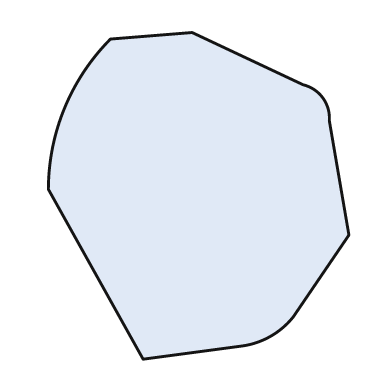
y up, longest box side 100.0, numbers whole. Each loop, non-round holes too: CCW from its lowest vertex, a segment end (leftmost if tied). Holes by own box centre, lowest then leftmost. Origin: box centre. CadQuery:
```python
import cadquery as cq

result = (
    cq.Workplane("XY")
    .moveTo(-17.0, -50.0)
    .lineTo(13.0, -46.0)
    .threePointArc((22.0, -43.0), (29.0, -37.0))
    .lineTo(46.0, -12.0)
    .lineTo(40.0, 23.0)
    .threePointArc((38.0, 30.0), (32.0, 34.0))
    .lineTo(-2.0, 50.0)
    .lineTo(-27.0, 48.0)
    .threePointArc((-41.0, 27.0), (-46.0, 2.0))
    .close()
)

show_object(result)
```